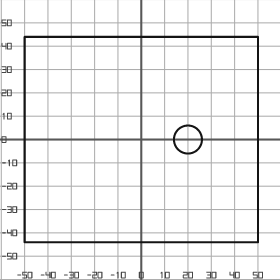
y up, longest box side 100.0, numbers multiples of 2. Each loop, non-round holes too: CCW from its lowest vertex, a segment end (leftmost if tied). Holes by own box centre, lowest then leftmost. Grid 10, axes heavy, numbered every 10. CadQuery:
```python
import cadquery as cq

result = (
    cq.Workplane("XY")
    .moveTo(-50.0, -44.0)
    .lineTo(50.0, -44.0)
    .lineTo(50.0, 44.0)
    .lineTo(-50.0, 44.0)
    .close()
    .moveTo(20.0, 0.0)
    .circle(6.0)
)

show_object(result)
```